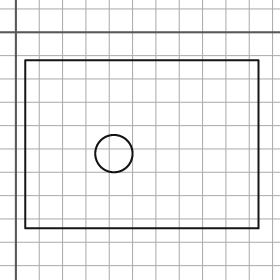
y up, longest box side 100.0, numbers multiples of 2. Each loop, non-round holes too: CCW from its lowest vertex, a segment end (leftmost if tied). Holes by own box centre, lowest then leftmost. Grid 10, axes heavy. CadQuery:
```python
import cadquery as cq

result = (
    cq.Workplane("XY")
    .moveTo(4.0, -84.0)
    .lineTo(104.0, -84.0)
    .lineTo(104.0, -12.0)
    .lineTo(4.0, -12.0)
    .close()
    .moveTo(42.0, -52.0)
    .circle(8.0)
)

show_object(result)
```